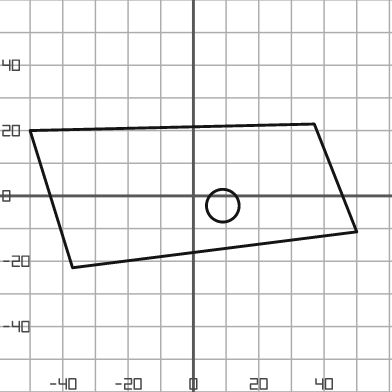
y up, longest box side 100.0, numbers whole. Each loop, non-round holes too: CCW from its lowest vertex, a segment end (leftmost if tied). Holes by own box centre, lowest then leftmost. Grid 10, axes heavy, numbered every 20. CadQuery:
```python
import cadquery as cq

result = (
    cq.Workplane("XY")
    .moveTo(-37.0, -22.0)
    .lineTo(50.0, -11.0)
    .lineTo(37.0, 22.0)
    .lineTo(-50.0, 20.0)
    .close()
    .moveTo(9.0, -3.0)
    .circle(5.0)
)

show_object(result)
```